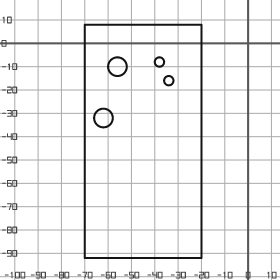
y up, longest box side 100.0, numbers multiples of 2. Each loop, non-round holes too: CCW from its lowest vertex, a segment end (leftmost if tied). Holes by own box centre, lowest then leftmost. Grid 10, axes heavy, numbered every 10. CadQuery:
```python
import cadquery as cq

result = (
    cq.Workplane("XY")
    .moveTo(-70.0, -92.0)
    .lineTo(-20.0, -92.0)
    .lineTo(-20.0, 8.0)
    .lineTo(-70.0, 8.0)
    .close()
    .moveTo(-62.0, -32.0)
    .circle(4.0)
    .moveTo(-34.0, -16.0)
    .circle(2.0)
    .moveTo(-56.0, -10.0)
    .circle(4.0)
    .moveTo(-38.0, -8.0)
    .circle(2.0)
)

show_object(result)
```